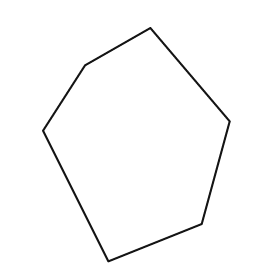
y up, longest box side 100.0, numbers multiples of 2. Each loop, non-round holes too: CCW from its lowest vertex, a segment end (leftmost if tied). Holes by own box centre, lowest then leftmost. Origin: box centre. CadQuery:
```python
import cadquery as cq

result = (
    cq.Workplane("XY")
    .moveTo(-12.0, -50.0)
    .lineTo(28.0, -34.0)
    .lineTo(40.0, 10.0)
    .lineTo(6.0, 50.0)
    .lineTo(-22.0, 34.0)
    .lineTo(-40.0, 6.0)
    .close()
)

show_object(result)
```